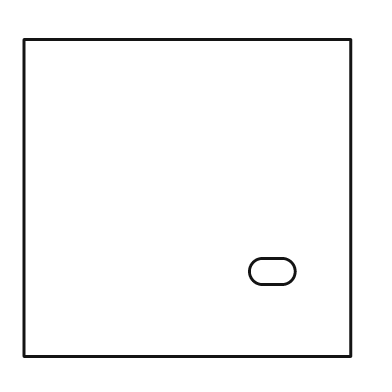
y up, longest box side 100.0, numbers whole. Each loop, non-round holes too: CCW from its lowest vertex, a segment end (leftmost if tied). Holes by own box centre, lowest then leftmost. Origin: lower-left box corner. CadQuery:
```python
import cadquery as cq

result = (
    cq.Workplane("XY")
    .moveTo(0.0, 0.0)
    .lineTo(100.0, 0.0)
    .lineTo(100.0, 97.0)
    .lineTo(0.0, 97.0)
    .close()
    .moveTo(73.0, 22.0)
    .lineTo(79.0, 22.0)
    .threePointArc((83.0, 26.0), (79.0, 30.0))
    .lineTo(73.0, 30.0)
    .threePointArc((69.0, 26.0), (73.0, 22.0))
    .close()
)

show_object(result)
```